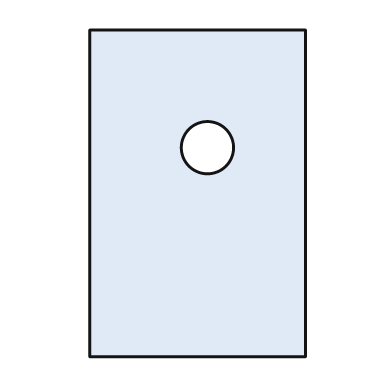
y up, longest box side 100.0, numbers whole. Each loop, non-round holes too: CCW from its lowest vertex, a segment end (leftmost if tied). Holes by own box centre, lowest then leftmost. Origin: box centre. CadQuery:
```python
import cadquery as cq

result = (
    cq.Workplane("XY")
    .moveTo(-33.0, -50.0)
    .lineTo(33.0, -50.0)
    .lineTo(33.0, 50.0)
    .lineTo(-33.0, 50.0)
    .close()
    .moveTo(3.0, 14.0)
    .circle(8.0)
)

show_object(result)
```